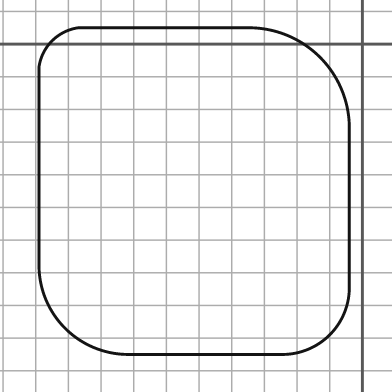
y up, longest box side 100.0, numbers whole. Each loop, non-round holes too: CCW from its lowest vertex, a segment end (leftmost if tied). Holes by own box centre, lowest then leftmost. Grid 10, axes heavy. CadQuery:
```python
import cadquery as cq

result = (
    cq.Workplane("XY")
    .moveTo(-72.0, -95.0)
    .lineTo(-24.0, -95.0)
    .threePointArc((-10.0, -89.0), (-4.0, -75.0))
    .lineTo(-4.0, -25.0)
    .threePointArc((-13.0, -4.0), (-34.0, 5.0))
    .lineTo(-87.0, 5.0)
    .threePointArc((-95.0, 1.0), (-99.0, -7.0))
    .lineTo(-99.0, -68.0)
    .threePointArc((-91.0, -87.0), (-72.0, -95.0))
    .close()
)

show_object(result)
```